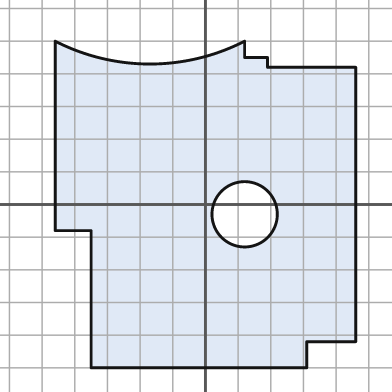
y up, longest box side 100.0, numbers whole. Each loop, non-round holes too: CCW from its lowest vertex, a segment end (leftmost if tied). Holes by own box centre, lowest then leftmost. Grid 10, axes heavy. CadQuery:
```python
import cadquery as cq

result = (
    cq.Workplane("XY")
    .moveTo(-35.0, -50.0)
    .lineTo(31.0, -50.0)
    .lineTo(31.0, -42.0)
    .lineTo(46.0, -42.0)
    .lineTo(46.0, 42.0)
    .lineTo(19.0, 42.0)
    .lineTo(19.0, 45.0)
    .lineTo(12.0, 45.0)
    .lineTo(12.0, 50.0)
    .threePointArc((-17.0, 43.0), (-46.0, 50.0))
    .lineTo(-46.0, -8.0)
    .lineTo(-35.0, -8.0)
    .close()
    .moveTo(12.0, -3.0)
    .circle(10.0)
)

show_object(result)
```